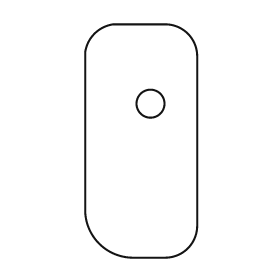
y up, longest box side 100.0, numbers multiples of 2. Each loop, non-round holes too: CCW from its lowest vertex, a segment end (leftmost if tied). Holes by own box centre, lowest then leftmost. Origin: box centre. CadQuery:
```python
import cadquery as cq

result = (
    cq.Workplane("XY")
    .moveTo(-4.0, -50.0)
    .lineTo(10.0, -50.0)
    .threePointArc((20.0, -46.0), (24.0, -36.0))
    .lineTo(24.0, 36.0)
    .threePointArc((20.0, 46.0), (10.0, 50.0))
    .lineTo(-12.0, 50.0)
    .threePointArc((-20.0, 46.0), (-24.0, 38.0))
    .lineTo(-24.0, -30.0)
    .threePointArc((-18.0, -44.0), (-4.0, -50.0))
    .close()
    .moveTo(4.0, 16.0)
    .circle(6.0)
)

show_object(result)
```